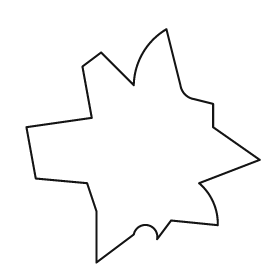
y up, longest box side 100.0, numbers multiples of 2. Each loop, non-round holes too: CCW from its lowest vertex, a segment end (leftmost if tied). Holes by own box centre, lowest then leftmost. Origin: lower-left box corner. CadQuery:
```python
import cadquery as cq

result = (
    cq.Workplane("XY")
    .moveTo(30.0, 0.0)
    .lineTo(46.0, 12.0)
    .threePointArc((52.0, 16.0), (56.0, 10.0))
    .lineTo(62.0, 18.0)
    .lineTo(82.0, 16.0)
    .threePointArc((80.0, 26.0), (74.0, 34.0))
    .lineTo(100.0, 44.0)
    .lineTo(80.0, 58.0)
    .lineTo(80.0, 68.0)
    .lineTo(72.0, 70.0)
    .threePointArc((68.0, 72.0), (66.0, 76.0))
    .lineTo(60.0, 100.0)
    .threePointArc((50.0, 90.0), (46.0, 76.0))
    .lineTo(32.0, 90.0)
    .lineTo(24.0, 84.0)
    .lineTo(28.0, 62.0)
    .lineTo(0.0, 58.0)
    .lineTo(4.0, 36.0)
    .lineTo(26.0, 34.0)
    .lineTo(30.0, 22.0)
    .close()
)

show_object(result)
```